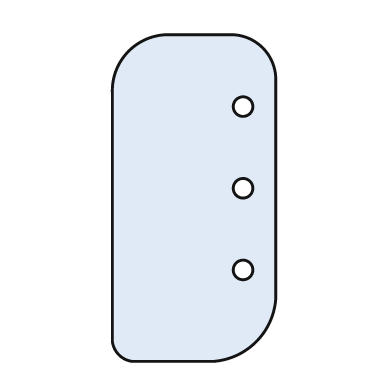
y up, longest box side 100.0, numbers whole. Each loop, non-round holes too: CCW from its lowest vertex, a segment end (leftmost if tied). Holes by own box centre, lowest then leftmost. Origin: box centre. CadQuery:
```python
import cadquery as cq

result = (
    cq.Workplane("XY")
    .moveTo(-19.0, -50.0)
    .lineTo(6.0, -50.0)
    .threePointArc((19.0, -44.0), (25.0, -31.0))
    .lineTo(25.0, 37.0)
    .threePointArc((21.0, 46.0), (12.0, 50.0))
    .lineTo(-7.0, 50.0)
    .threePointArc((-20.0, 45.0), (-25.0, 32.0))
    .lineTo(-25.0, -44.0)
    .threePointArc((-23.0, -48.0), (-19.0, -50.0))
    .close()
    .moveTo(15.0, -22.0)
    .circle(3.0)
    .moveTo(15.0, 3.0)
    .circle(3.0)
    .moveTo(15.0, 28.0)
    .circle(3.0)
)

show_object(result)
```